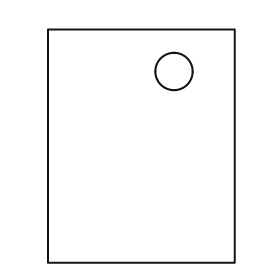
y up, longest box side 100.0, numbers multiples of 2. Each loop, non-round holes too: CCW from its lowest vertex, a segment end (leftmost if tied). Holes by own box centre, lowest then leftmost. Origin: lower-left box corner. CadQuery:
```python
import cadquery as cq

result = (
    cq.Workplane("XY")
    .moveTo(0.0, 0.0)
    .lineTo(80.0, 0.0)
    .lineTo(80.0, 100.0)
    .lineTo(0.0, 100.0)
    .close()
    .moveTo(54.0, 82.0)
    .circle(8.0)
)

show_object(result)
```